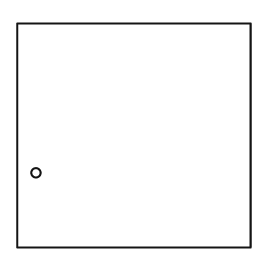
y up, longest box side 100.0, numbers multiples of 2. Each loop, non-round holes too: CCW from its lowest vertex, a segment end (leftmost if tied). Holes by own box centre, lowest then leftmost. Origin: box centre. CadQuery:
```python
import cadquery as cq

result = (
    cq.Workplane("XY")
    .moveTo(-50.0, -48.0)
    .lineTo(50.0, -48.0)
    .lineTo(50.0, 48.0)
    .lineTo(-50.0, 48.0)
    .close()
    .moveTo(-42.0, -16.0)
    .circle(2.0)
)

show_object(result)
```